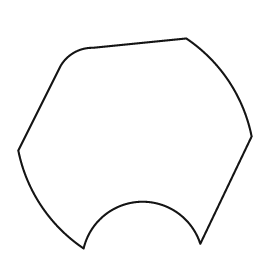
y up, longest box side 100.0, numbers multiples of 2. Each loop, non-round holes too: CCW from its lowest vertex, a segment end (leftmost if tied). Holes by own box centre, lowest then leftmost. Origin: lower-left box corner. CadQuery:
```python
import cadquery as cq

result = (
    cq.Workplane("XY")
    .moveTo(28.0, 0.0)
    .threePointArc((52.0, 20.0), (78.0, 2.0))
    .lineTo(100.0, 48.0)
    .threePointArc((90.0, 72.0), (72.0, 90.0))
    .lineTo(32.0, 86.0)
    .threePointArc((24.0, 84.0), (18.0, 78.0))
    .lineTo(0.0, 42.0)
    .threePointArc((10.0, 18.0), (28.0, 0.0))
    .close()
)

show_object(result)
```